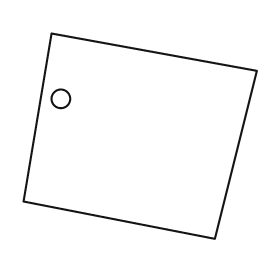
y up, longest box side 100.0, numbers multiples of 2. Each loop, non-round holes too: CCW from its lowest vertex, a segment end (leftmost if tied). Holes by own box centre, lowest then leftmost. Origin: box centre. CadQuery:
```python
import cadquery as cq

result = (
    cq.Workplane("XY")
    .moveTo(32.0, -44.0)
    .lineTo(50.0, 28.0)
    .lineTo(-38.0, 44.0)
    .lineTo(-50.0, -28.0)
    .close()
    .moveTo(-34.0, 16.0)
    .circle(4.0)
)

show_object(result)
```